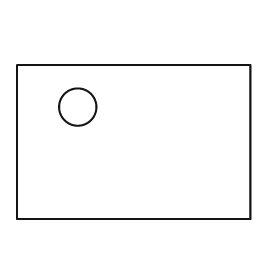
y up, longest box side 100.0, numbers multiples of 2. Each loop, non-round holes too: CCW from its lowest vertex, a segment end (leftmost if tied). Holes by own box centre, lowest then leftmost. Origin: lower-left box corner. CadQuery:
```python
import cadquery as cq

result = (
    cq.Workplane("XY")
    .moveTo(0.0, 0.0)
    .lineTo(100.0, 0.0)
    .lineTo(100.0, 66.0)
    .lineTo(0.0, 66.0)
    .close()
    .moveTo(26.0, 48.0)
    .circle(8.0)
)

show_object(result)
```